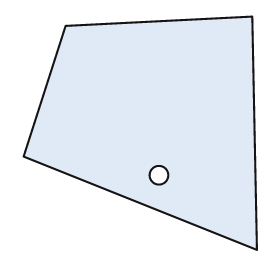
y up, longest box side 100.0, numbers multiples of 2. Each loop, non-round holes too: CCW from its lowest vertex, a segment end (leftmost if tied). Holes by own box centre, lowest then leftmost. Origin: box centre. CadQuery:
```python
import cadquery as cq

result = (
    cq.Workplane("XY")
    .moveTo(50.0, -50.0)
    .lineTo(48.0, 50.0)
    .lineTo(-32.0, 46.0)
    .lineTo(-50.0, -10.0)
    .close()
    .moveTo(8.0, -18.0)
    .circle(4.0)
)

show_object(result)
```